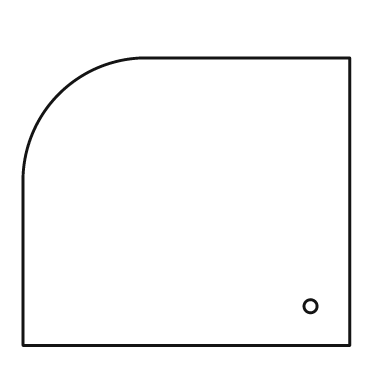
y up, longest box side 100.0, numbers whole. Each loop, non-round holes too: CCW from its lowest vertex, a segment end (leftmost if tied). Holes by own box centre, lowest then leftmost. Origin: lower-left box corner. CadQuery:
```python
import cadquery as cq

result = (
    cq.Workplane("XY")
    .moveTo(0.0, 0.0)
    .lineTo(100.0, 0.0)
    .lineTo(100.0, 88.0)
    .lineTo(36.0, 88.0)
    .threePointArc((11.0, 77.0), (0.0, 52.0))
    .close()
    .moveTo(88.0, 12.0)
    .circle(2.0)
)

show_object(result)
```